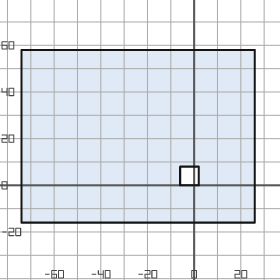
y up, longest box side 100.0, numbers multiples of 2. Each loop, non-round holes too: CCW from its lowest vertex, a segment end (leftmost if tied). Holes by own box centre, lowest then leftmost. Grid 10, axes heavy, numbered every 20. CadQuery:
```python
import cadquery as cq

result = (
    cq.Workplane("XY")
    .moveTo(-74.0, -16.0)
    .lineTo(26.0, -16.0)
    .lineTo(26.0, 58.0)
    .lineTo(-74.0, 58.0)
    .close()
    .moveTo(-6.0, 0.0)
    .lineTo(2.0, 0.0)
    .lineTo(2.0, 8.0)
    .lineTo(-6.0, 8.0)
    .close()
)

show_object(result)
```